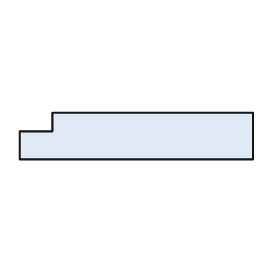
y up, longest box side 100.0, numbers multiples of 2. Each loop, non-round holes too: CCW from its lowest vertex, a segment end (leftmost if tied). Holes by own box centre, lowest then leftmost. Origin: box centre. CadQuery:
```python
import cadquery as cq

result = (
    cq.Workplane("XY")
    .moveTo(-50.0, -10.0)
    .lineTo(50.0, -10.0)
    .lineTo(50.0, 10.0)
    .lineTo(-36.0, 10.0)
    .lineTo(-36.0, 2.0)
    .lineTo(-50.0, 2.0)
    .close()
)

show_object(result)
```